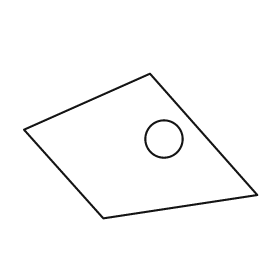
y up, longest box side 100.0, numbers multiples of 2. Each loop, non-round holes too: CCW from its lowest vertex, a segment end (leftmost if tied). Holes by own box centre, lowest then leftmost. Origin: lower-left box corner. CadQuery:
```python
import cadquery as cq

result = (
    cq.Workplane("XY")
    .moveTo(34.0, 0.0)
    .lineTo(100.0, 10.0)
    .lineTo(54.0, 62.0)
    .lineTo(0.0, 38.0)
    .close()
    .moveTo(60.0, 34.0)
    .circle(8.0)
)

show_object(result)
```